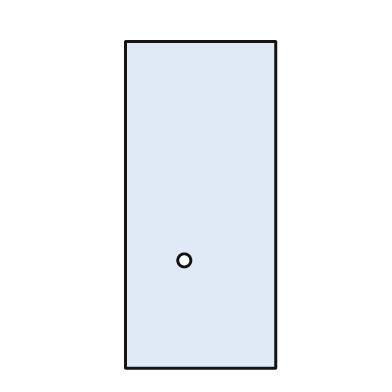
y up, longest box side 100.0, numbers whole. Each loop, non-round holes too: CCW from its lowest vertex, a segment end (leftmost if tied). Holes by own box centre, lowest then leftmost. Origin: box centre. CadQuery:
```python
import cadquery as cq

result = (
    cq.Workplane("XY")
    .moveTo(-23.0, -50.0)
    .lineTo(23.0, -50.0)
    .lineTo(23.0, 50.0)
    .lineTo(-23.0, 50.0)
    .close()
    .moveTo(-5.0, -17.0)
    .circle(2.0)
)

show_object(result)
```